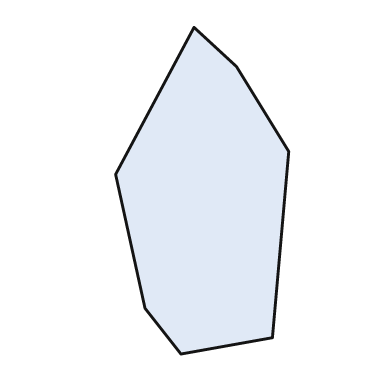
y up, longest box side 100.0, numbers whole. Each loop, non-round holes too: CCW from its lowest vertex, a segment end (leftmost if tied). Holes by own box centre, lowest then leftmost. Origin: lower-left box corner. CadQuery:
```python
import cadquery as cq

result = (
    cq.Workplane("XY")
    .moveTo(20.0, 0.0)
    .lineTo(48.0, 5.0)
    .lineTo(53.0, 62.0)
    .lineTo(37.0, 88.0)
    .lineTo(24.0, 100.0)
    .lineTo(0.0, 55.0)
    .lineTo(9.0, 14.0)
    .close()
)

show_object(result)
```